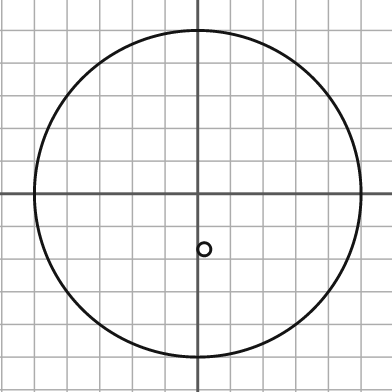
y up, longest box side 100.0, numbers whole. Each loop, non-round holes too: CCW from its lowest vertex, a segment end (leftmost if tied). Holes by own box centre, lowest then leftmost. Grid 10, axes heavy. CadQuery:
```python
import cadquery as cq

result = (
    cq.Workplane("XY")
    .moveTo(0.0, 0.0)
    .circle(50.0)
    .moveTo(2.0, -17.0)
    .circle(2.0)
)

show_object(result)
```